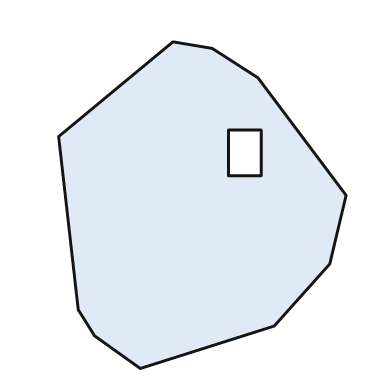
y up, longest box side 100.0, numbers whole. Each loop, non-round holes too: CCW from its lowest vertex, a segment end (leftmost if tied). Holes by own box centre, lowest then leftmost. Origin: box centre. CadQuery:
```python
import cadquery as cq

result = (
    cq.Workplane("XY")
    .moveTo(-19.0, -50.0)
    .lineTo(22.0, -37.0)
    .lineTo(39.0, -18.0)
    .lineTo(44.0, 3.0)
    .lineTo(17.0, 39.0)
    .lineTo(3.0, 48.0)
    .lineTo(-9.0, 50.0)
    .lineTo(-44.0, 21.0)
    .lineTo(-38.0, -32.0)
    .lineTo(-33.0, -40.0)
    .close()
    .moveTo(8.0, 9.0)
    .lineTo(18.0, 9.0)
    .lineTo(18.0, 23.0)
    .lineTo(8.0, 23.0)
    .close()
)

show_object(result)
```